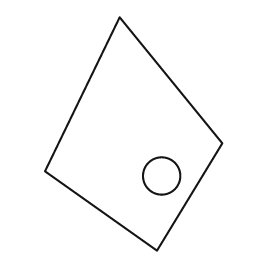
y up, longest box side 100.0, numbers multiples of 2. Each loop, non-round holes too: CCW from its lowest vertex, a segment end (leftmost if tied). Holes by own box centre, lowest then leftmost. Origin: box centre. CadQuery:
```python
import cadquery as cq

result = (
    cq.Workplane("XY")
    .moveTo(10.0, -50.0)
    .lineTo(38.0, -4.0)
    .lineTo(-6.0, 50.0)
    .lineTo(-38.0, -16.0)
    .close()
    .moveTo(12.0, -18.0)
    .circle(8.0)
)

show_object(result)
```